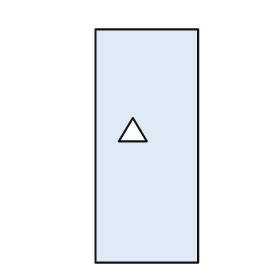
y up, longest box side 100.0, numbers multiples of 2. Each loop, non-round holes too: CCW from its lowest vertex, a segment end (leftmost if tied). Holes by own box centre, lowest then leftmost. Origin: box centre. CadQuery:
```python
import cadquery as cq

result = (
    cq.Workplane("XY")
    .moveTo(-22.0, -50.0)
    .lineTo(22.0, -50.0)
    .lineTo(22.0, 50.0)
    .lineTo(-22.0, 50.0)
    .close()
    .moveTo(-12.0, 2.0)
    .lineTo(0.0, 2.0)
    .lineTo(-6.0, 12.0)
    .close()
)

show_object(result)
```